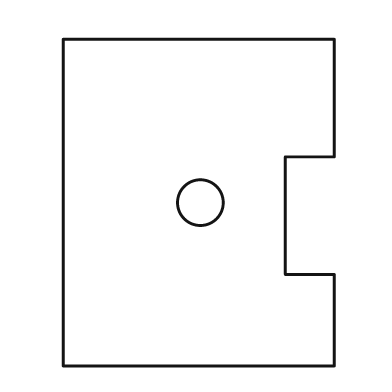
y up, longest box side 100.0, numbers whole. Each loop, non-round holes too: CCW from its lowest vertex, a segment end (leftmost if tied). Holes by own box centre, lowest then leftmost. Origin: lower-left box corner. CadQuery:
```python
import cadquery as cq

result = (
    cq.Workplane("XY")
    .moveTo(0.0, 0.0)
    .lineTo(83.0, 0.0)
    .lineTo(83.0, 28.0)
    .lineTo(68.0, 28.0)
    .lineTo(68.0, 64.0)
    .lineTo(83.0, 64.0)
    .lineTo(83.0, 100.0)
    .lineTo(0.0, 100.0)
    .close()
    .moveTo(42.0, 50.0)
    .circle(7.0)
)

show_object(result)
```